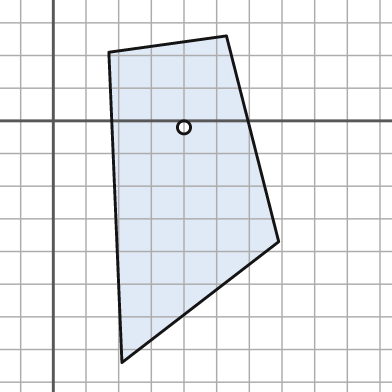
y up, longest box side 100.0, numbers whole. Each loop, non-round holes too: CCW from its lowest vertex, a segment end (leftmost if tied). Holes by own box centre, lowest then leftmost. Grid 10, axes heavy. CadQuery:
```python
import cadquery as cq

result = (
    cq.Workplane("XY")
    .moveTo(21.0, -74.0)
    .lineTo(69.0, -37.0)
    .lineTo(53.0, 26.0)
    .lineTo(17.0, 21.0)
    .close()
    .moveTo(40.0, -2.0)
    .circle(2.0)
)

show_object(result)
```